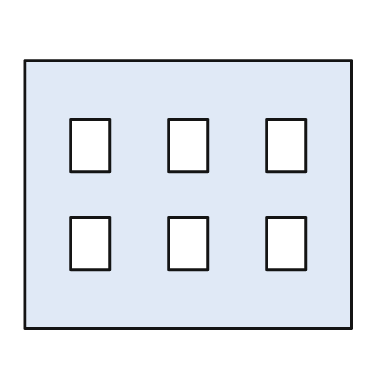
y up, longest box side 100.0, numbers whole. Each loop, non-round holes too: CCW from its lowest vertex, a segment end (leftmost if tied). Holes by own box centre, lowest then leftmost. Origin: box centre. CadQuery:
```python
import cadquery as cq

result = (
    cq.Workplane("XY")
    .moveTo(-50.0, -41.0)
    .lineTo(50.0, -41.0)
    .lineTo(50.0, 41.0)
    .lineTo(-50.0, 41.0)
    .close()
    .moveTo(-36.0, -23.0)
    .lineTo(-24.0, -23.0)
    .lineTo(-24.0, -7.0)
    .lineTo(-36.0, -7.0)
    .close()
    .moveTo(-6.0, -23.0)
    .lineTo(6.0, -23.0)
    .lineTo(6.0, -7.0)
    .lineTo(-6.0, -7.0)
    .close()
    .moveTo(24.0, -23.0)
    .lineTo(36.0, -23.0)
    .lineTo(36.0, -7.0)
    .lineTo(24.0, -7.0)
    .close()
    .moveTo(-36.0, 7.0)
    .lineTo(-24.0, 7.0)
    .lineTo(-24.0, 23.0)
    .lineTo(-36.0, 23.0)
    .close()
    .moveTo(-6.0, 7.0)
    .lineTo(6.0, 7.0)
    .lineTo(6.0, 23.0)
    .lineTo(-6.0, 23.0)
    .close()
    .moveTo(24.0, 7.0)
    .lineTo(36.0, 7.0)
    .lineTo(36.0, 23.0)
    .lineTo(24.0, 23.0)
    .close()
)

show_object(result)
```